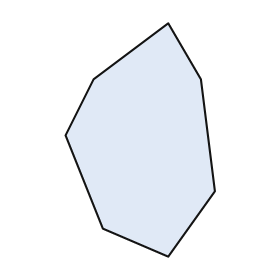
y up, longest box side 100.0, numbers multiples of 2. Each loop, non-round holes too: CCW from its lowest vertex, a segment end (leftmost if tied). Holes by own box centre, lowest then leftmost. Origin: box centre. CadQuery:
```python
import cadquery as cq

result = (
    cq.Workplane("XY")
    .moveTo(12.0, -50.0)
    .lineTo(32.0, -22.0)
    .lineTo(26.0, 26.0)
    .lineTo(12.0, 50.0)
    .lineTo(-20.0, 26.0)
    .lineTo(-32.0, 2.0)
    .lineTo(-16.0, -38.0)
    .close()
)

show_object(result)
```